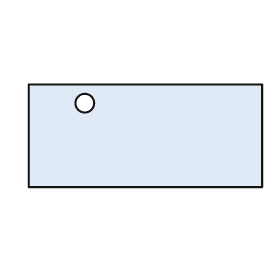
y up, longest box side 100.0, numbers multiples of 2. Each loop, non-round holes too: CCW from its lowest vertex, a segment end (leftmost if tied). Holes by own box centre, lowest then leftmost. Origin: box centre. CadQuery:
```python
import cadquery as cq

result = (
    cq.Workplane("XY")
    .moveTo(-50.0, -22.0)
    .lineTo(50.0, -22.0)
    .lineTo(50.0, 22.0)
    .lineTo(-50.0, 22.0)
    .close()
    .moveTo(-26.0, 14.0)
    .circle(4.0)
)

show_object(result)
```